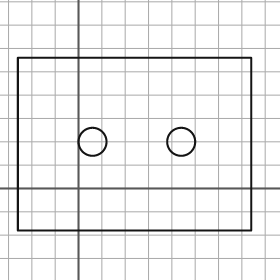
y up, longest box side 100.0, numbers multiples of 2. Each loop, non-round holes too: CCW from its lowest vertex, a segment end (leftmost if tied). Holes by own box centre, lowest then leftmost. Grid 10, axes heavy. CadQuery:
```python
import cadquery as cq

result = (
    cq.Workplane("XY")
    .moveTo(-26.0, -18.0)
    .lineTo(74.0, -18.0)
    .lineTo(74.0, 56.0)
    .lineTo(-26.0, 56.0)
    .close()
    .moveTo(6.0, 20.0)
    .circle(6.0)
    .moveTo(44.0, 20.0)
    .circle(6.0)
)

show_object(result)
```